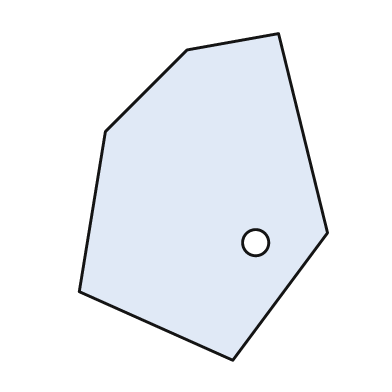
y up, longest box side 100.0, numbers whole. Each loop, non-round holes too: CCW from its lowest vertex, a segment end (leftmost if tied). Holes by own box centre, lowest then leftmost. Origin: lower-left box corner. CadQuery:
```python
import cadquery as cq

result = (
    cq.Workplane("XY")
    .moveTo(47.0, 0.0)
    .lineTo(76.0, 39.0)
    .lineTo(61.0, 100.0)
    .lineTo(33.0, 95.0)
    .lineTo(8.0, 70.0)
    .lineTo(0.0, 21.0)
    .close()
    .moveTo(54.0, 36.0)
    .circle(4.0)
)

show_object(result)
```